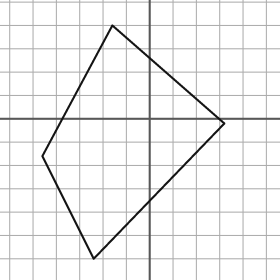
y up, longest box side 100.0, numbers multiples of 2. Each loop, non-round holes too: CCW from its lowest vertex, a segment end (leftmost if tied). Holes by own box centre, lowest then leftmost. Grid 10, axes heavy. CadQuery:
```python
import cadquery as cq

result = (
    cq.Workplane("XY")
    .moveTo(-24.0, -60.0)
    .lineTo(32.0, -2.0)
    .lineTo(-16.0, 40.0)
    .lineTo(-46.0, -16.0)
    .close()
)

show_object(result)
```